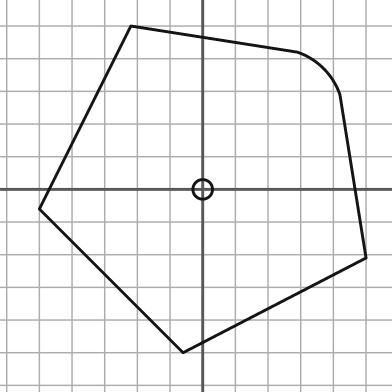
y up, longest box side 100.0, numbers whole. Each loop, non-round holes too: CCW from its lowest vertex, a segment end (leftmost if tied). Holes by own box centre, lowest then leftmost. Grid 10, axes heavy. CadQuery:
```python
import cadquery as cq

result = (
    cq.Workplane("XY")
    .moveTo(-6.0, -50.0)
    .lineTo(50.0, -21.0)
    .lineTo(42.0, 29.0)
    .threePointArc((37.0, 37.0), (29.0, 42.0))
    .lineTo(-22.0, 50.0)
    .lineTo(-50.0, -6.0)
    .close()
    .moveTo(0.0, 0.0)
    .circle(3.0)
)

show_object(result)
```